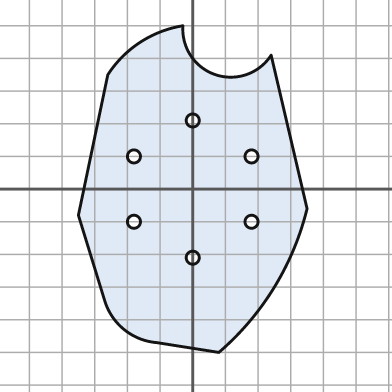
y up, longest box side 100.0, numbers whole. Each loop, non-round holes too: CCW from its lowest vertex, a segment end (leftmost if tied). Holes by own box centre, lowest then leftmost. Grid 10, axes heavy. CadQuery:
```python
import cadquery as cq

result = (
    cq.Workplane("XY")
    .moveTo(8.0, -50.0)
    .threePointArc((25.0, -30.0), (35.0, -6.0))
    .lineTo(24.0, 41.0)
    .threePointArc((7.0, 35.0), (-3.0, 50.0))
    .threePointArc((-16.0, 45.0), (-26.0, 35.0))
    .lineTo(-35.0, -8.0)
    .lineTo(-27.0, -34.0)
    .threePointArc((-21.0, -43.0), (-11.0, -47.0))
    .close()
    .moveTo(0.0, -21.0)
    .circle(2.0)
    .moveTo(-18.0, -10.0)
    .circle(2.0)
    .moveTo(18.0, -10.0)
    .circle(2.0)
    .moveTo(-18.0, 10.0)
    .circle(2.0)
    .moveTo(18.0, 10.0)
    .circle(2.0)
    .moveTo(0.0, 21.0)
    .circle(2.0)
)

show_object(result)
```